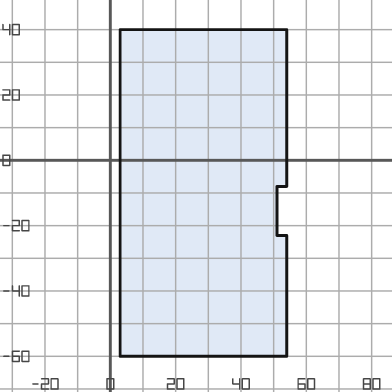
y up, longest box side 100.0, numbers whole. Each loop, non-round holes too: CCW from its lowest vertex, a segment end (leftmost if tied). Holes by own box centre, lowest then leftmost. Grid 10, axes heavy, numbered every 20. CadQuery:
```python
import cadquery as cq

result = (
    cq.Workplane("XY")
    .moveTo(3.0, -60.0)
    .lineTo(54.0, -60.0)
    .lineTo(54.0, -23.0)
    .lineTo(51.0, -23.0)
    .lineTo(51.0, -8.0)
    .lineTo(54.0, -8.0)
    .lineTo(54.0, 40.0)
    .lineTo(3.0, 40.0)
    .close()
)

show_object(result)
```